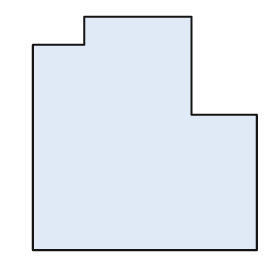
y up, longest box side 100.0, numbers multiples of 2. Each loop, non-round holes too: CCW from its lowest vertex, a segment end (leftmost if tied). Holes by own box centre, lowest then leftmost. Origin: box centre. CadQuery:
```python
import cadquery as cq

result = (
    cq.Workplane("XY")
    .moveTo(-48.0, -50.0)
    .lineTo(48.0, -50.0)
    .lineTo(48.0, 8.0)
    .lineTo(20.0, 8.0)
    .lineTo(20.0, 50.0)
    .lineTo(-26.0, 50.0)
    .lineTo(-26.0, 38.0)
    .lineTo(-48.0, 38.0)
    .close()
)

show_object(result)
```